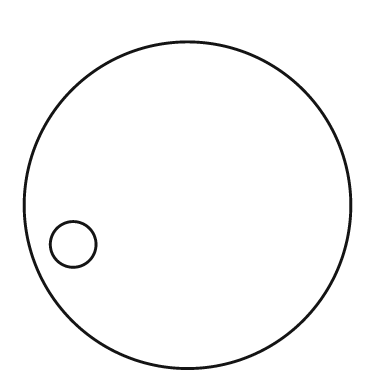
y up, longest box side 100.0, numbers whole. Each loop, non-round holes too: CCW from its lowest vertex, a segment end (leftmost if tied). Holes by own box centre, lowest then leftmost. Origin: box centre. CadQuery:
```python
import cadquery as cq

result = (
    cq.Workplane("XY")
    .moveTo(0.0, 0.0)
    .circle(50.0)
    .moveTo(-35.0, -12.0)
    .circle(7.0)
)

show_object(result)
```